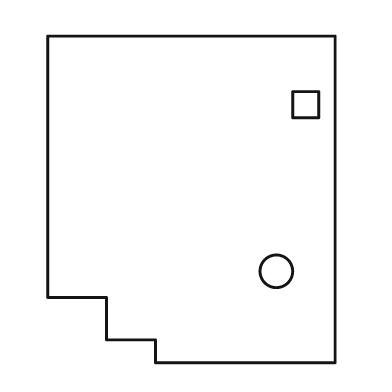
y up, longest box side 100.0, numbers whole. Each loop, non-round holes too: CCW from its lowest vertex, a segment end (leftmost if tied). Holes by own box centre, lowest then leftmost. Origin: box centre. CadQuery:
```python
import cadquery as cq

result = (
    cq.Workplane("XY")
    .moveTo(-11.0, -50.0)
    .lineTo(44.0, -50.0)
    .lineTo(44.0, 50.0)
    .lineTo(-44.0, 50.0)
    .lineTo(-44.0, -30.0)
    .lineTo(-26.0, -30.0)
    .lineTo(-26.0, -43.0)
    .lineTo(-11.0, -43.0)
    .close()
    .moveTo(26.0, -22.0)
    .circle(5.0)
    .moveTo(31.0, 25.0)
    .lineTo(39.0, 25.0)
    .lineTo(39.0, 33.0)
    .lineTo(31.0, 33.0)
    .close()
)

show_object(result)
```